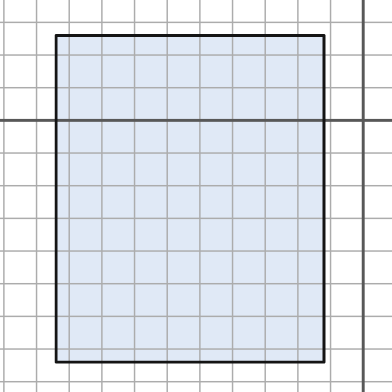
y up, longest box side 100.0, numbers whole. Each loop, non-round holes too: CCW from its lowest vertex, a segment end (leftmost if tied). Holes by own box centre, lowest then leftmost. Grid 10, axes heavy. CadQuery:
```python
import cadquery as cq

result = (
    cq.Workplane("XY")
    .moveTo(-94.0, -74.0)
    .lineTo(-12.0, -74.0)
    .lineTo(-12.0, 26.0)
    .lineTo(-94.0, 26.0)
    .close()
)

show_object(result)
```